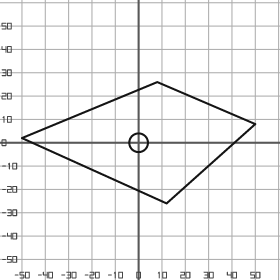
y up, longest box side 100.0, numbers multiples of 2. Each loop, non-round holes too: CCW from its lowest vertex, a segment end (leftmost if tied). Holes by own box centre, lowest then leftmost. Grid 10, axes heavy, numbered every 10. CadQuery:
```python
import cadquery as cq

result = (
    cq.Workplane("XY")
    .moveTo(12.0, -26.0)
    .lineTo(50.0, 8.0)
    .lineTo(8.0, 26.0)
    .lineTo(-50.0, 2.0)
    .close()
    .moveTo(0.0, 0.0)
    .circle(4.0)
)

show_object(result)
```